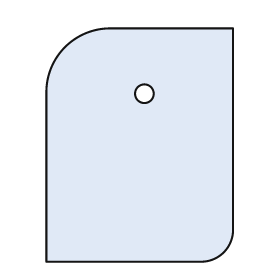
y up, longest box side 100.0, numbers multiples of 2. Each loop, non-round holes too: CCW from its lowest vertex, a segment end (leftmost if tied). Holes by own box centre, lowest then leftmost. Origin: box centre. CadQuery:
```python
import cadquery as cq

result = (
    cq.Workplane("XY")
    .moveTo(-40.0, -50.0)
    .lineTo(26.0, -50.0)
    .threePointArc((36.0, -46.0), (40.0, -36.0))
    .lineTo(40.0, 50.0)
    .lineTo(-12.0, 50.0)
    .threePointArc((-32.0, 42.0), (-40.0, 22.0))
    .close()
    .moveTo(2.0, 22.0)
    .circle(4.0)
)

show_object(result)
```